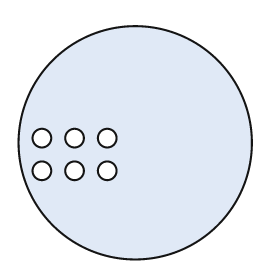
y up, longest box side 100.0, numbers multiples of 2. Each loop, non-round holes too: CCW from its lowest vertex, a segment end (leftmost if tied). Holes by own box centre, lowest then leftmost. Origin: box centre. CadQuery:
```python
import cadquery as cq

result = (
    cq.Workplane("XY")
    .moveTo(0.0, 0.0)
    .circle(50.0)
    .moveTo(-40.0, -12.0)
    .circle(4.0)
    .moveTo(-26.0, -12.0)
    .circle(4.0)
    .moveTo(-12.0, -12.0)
    .circle(4.0)
    .moveTo(-40.0, 2.0)
    .circle(4.0)
    .moveTo(-26.0, 2.0)
    .circle(4.0)
    .moveTo(-12.0, 2.0)
    .circle(4.0)
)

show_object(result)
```